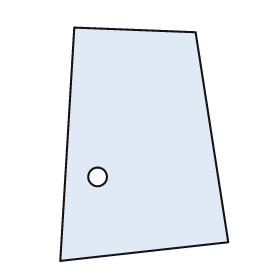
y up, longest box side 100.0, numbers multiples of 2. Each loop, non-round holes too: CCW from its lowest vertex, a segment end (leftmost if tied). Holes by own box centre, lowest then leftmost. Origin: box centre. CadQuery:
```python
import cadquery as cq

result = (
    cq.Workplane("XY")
    .moveTo(-36.0, -50.0)
    .lineTo(36.0, -42.0)
    .lineTo(22.0, 48.0)
    .lineTo(-30.0, 50.0)
    .close()
    .moveTo(-20.0, -14.0)
    .circle(4.0)
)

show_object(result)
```